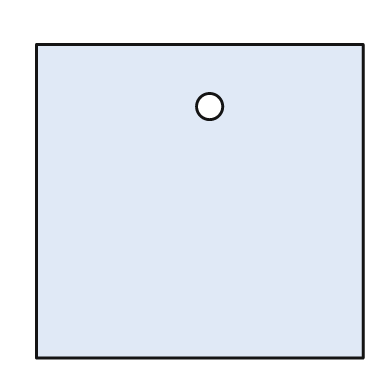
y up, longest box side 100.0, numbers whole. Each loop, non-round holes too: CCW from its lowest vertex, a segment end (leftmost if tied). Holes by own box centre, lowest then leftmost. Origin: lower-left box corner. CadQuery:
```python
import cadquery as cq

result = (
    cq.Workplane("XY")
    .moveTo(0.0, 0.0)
    .lineTo(100.0, 0.0)
    .lineTo(100.0, 96.0)
    .lineTo(0.0, 96.0)
    .close()
    .moveTo(53.0, 77.0)
    .circle(4.0)
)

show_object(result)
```